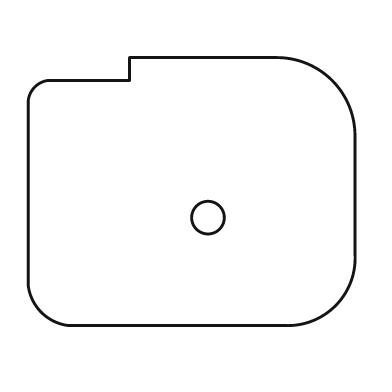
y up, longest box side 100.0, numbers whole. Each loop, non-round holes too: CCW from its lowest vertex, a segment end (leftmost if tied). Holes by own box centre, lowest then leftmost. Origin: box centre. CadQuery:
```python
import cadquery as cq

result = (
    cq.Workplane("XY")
    .moveTo(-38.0, -41.0)
    .lineTo(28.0, -41.0)
    .threePointArc((44.0, -35.0), (50.0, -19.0))
    .lineTo(50.0, 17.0)
    .threePointArc((43.0, 34.0), (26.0, 41.0))
    .lineTo(-19.0, 41.0)
    .lineTo(-19.0, 34.0)
    .lineTo(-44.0, 34.0)
    .threePointArc((-48.0, 32.0), (-50.0, 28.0))
    .lineTo(-50.0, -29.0)
    .threePointArc((-46.0, -37.0), (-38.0, -41.0))
    .close()
    .moveTo(5.0, -8.0)
    .circle(5.0)
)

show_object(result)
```